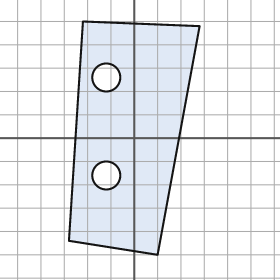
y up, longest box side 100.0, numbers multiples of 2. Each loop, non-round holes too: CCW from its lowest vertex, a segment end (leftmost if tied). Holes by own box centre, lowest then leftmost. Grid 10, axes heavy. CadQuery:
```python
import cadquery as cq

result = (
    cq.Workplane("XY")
    .moveTo(10.0, -50.0)
    .lineTo(28.0, 48.0)
    .lineTo(-22.0, 50.0)
    .lineTo(-28.0, -44.0)
    .close()
    .moveTo(-12.0, -16.0)
    .circle(6.0)
    .moveTo(-12.0, 26.0)
    .circle(6.0)
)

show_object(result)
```